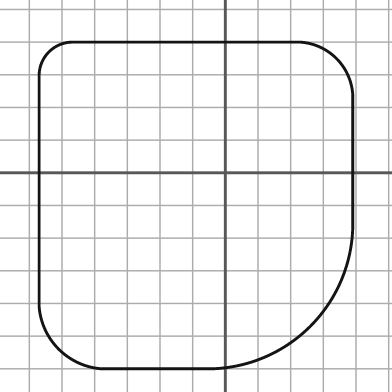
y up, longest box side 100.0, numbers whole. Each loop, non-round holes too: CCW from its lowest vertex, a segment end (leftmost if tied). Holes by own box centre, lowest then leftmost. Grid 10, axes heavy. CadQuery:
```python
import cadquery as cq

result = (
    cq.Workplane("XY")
    .moveTo(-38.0, -60.0)
    .lineTo(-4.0, -60.0)
    .threePointArc((26.0, -47.0), (39.0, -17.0))
    .lineTo(39.0, 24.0)
    .threePointArc((34.0, 35.0), (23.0, 40.0))
    .lineTo(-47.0, 40.0)
    .threePointArc((-54.0, 37.0), (-57.0, 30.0))
    .lineTo(-57.0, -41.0)
    .threePointArc((-51.0, -54.0), (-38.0, -60.0))
    .close()
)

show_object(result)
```